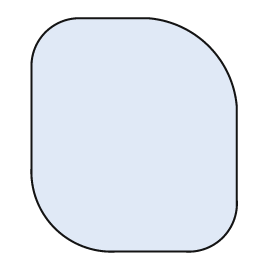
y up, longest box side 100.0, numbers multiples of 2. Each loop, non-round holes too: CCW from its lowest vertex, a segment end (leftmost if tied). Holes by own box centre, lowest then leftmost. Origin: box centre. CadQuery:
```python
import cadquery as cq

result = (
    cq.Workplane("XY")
    .moveTo(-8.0, -50.0)
    .lineTo(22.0, -50.0)
    .threePointArc((38.0, -44.0), (44.0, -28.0))
    .lineTo(44.0, 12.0)
    .threePointArc((32.0, 38.0), (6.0, 50.0))
    .lineTo(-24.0, 50.0)
    .threePointArc((-38.0, 44.0), (-44.0, 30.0))
    .lineTo(-44.0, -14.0)
    .threePointArc((-34.0, -40.0), (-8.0, -50.0))
    .close()
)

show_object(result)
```